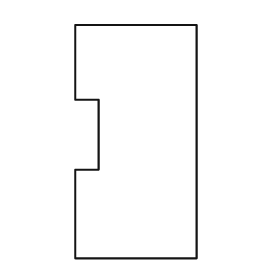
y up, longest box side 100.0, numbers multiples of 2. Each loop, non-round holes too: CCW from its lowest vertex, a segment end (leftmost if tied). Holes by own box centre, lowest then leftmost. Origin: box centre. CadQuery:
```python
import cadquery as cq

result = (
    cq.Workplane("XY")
    .moveTo(-26.0, -50.0)
    .lineTo(26.0, -50.0)
    .lineTo(26.0, 50.0)
    .lineTo(-26.0, 50.0)
    .lineTo(-26.0, 18.0)
    .lineTo(-16.0, 18.0)
    .lineTo(-16.0, -12.0)
    .lineTo(-26.0, -12.0)
    .close()
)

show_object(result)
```